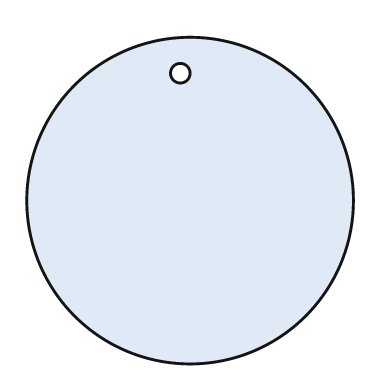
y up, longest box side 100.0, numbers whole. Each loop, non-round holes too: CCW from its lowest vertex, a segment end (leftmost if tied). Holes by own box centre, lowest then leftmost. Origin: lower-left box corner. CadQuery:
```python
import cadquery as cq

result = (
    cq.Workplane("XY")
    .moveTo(50.0, 50.0)
    .circle(50.0)
    .moveTo(47.0, 89.0)
    .circle(3.0)
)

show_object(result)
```